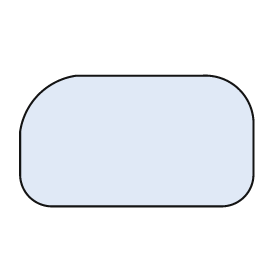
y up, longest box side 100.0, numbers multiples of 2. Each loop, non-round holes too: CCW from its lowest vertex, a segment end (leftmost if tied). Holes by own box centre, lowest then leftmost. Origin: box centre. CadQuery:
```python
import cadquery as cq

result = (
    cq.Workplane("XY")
    .moveTo(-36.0, -28.0)
    .lineTo(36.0, -28.0)
    .threePointArc((46.0, -24.0), (50.0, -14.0))
    .lineTo(50.0, 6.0)
    .threePointArc((44.0, 22.0), (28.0, 28.0))
    .lineTo(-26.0, 28.0)
    .threePointArc((-42.0, 20.0), (-50.0, 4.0))
    .lineTo(-50.0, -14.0)
    .threePointArc((-46.0, -24.0), (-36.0, -28.0))
    .close()
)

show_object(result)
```